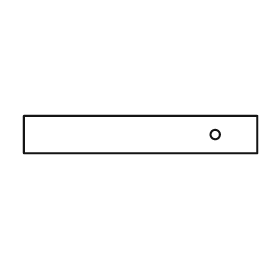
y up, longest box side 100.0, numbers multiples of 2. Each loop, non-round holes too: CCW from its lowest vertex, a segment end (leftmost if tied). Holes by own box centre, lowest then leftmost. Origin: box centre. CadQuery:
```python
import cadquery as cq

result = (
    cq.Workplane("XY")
    .moveTo(-50.0, -8.0)
    .lineTo(50.0, -8.0)
    .lineTo(50.0, 8.0)
    .lineTo(-50.0, 8.0)
    .close()
    .moveTo(32.0, 0.0)
    .circle(2.0)
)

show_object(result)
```